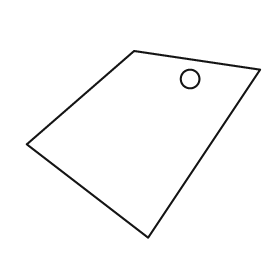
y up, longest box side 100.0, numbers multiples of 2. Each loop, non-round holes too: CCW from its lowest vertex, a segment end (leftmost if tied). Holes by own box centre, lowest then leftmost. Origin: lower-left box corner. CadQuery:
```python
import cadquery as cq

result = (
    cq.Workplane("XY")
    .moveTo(52.0, 0.0)
    .lineTo(100.0, 72.0)
    .lineTo(46.0, 80.0)
    .lineTo(0.0, 40.0)
    .close()
    .moveTo(70.0, 68.0)
    .circle(4.0)
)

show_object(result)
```